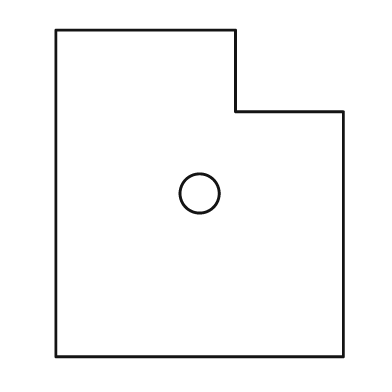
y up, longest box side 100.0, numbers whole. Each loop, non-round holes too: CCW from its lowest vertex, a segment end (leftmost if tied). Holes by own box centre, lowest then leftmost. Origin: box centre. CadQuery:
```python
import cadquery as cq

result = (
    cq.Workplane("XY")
    .moveTo(-44.0, -50.0)
    .lineTo(44.0, -50.0)
    .lineTo(44.0, 25.0)
    .lineTo(11.0, 25.0)
    .lineTo(11.0, 50.0)
    .lineTo(-44.0, 50.0)
    .close()
    .moveTo(0.0, 0.0)
    .circle(6.0)
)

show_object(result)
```